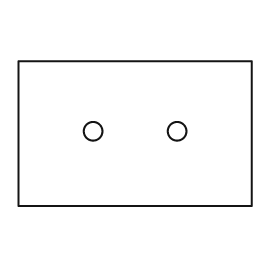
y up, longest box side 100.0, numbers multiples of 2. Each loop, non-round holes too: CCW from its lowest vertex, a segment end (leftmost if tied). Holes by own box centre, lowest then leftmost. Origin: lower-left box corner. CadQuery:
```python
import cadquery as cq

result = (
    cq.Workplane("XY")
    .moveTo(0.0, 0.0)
    .lineTo(100.0, 0.0)
    .lineTo(100.0, 62.0)
    .lineTo(0.0, 62.0)
    .close()
    .moveTo(32.0, 32.0)
    .circle(4.0)
    .moveTo(68.0, 32.0)
    .circle(4.0)
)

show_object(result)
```